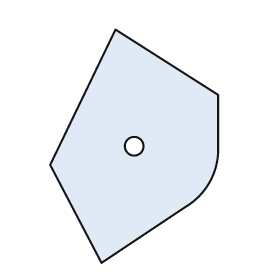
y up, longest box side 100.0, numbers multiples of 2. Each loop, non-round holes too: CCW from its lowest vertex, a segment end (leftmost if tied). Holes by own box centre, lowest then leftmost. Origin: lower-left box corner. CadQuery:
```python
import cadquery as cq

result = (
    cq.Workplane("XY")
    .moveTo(22.0, 0.0)
    .lineTo(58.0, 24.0)
    .threePointArc((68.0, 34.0), (72.0, 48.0))
    .lineTo(72.0, 72.0)
    .lineTo(28.0, 100.0)
    .lineTo(0.0, 42.0)
    .close()
    .moveTo(36.0, 50.0)
    .circle(4.0)
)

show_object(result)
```